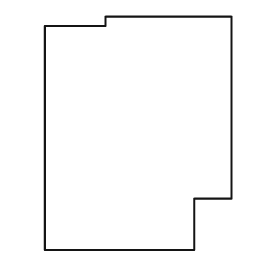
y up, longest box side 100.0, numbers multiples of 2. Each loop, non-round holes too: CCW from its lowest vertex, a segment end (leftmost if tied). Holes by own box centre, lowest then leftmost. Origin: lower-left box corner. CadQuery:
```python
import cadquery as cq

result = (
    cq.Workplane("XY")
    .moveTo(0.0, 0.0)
    .lineTo(64.0, 0.0)
    .lineTo(64.0, 22.0)
    .lineTo(80.0, 22.0)
    .lineTo(80.0, 100.0)
    .lineTo(26.0, 100.0)
    .lineTo(26.0, 96.0)
    .lineTo(0.0, 96.0)
    .close()
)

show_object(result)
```